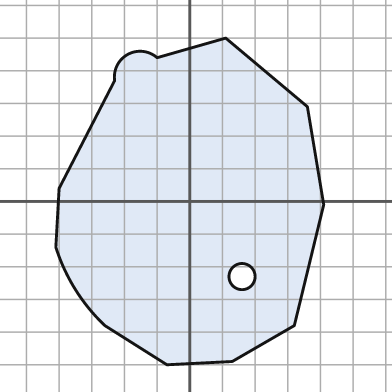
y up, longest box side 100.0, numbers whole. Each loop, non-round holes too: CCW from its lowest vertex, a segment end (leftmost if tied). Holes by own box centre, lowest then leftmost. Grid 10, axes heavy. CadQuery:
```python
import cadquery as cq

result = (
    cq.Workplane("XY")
    .moveTo(-7.0, -50.0)
    .lineTo(13.0, -49.0)
    .lineTo(32.0, -38.0)
    .lineTo(41.0, -1.0)
    .lineTo(36.0, 29.0)
    .lineTo(11.0, 50.0)
    .lineTo(-10.0, 44.0)
    .threePointArc((-19.0, 45.0), (-23.0, 37.0))
    .lineTo(-40.0, 4.0)
    .lineTo(-41.0, -14.0)
    .threePointArc((-35.0, -27.0), (-26.0, -38.0))
    .close()
    .moveTo(16.0, -23.0)
    .circle(4.0)
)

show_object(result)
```